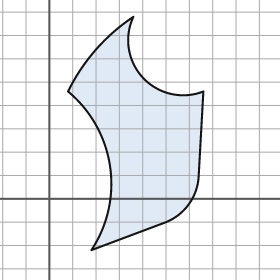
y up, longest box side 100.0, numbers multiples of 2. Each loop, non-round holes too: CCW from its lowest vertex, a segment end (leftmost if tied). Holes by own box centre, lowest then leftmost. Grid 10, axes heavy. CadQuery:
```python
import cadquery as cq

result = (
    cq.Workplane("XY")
    .moveTo(18.0, -22.0)
    .lineTo(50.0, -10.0)
    .threePointArc((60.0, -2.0), (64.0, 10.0))
    .lineTo(66.0, 46.0)
    .threePointArc((40.0, 52.0), (36.0, 78.0))
    .threePointArc((20.0, 64.0), (8.0, 46.0))
    .threePointArc((26.0, 14.0), (18.0, -22.0))
    .close()
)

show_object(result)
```